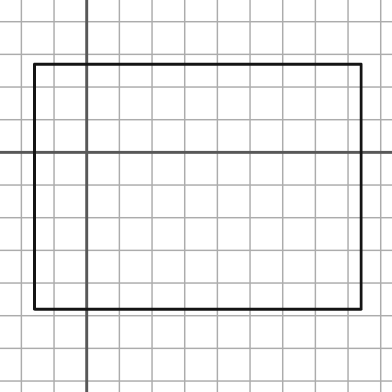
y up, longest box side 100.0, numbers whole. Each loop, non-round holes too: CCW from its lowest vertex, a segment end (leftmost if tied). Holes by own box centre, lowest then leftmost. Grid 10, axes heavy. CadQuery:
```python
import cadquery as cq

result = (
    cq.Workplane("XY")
    .moveTo(-16.0, -48.0)
    .lineTo(84.0, -48.0)
    .lineTo(84.0, 27.0)
    .lineTo(-16.0, 27.0)
    .close()
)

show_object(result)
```